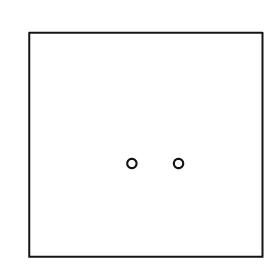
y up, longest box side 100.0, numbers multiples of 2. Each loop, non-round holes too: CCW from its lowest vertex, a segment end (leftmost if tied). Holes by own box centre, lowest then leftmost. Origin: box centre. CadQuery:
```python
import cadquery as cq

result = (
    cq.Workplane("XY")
    .moveTo(-50.0, -48.0)
    .lineTo(50.0, -48.0)
    .lineTo(50.0, 48.0)
    .lineTo(-50.0, 48.0)
    .close()
    .moveTo(-6.0, -8.0)
    .circle(2.0)
    .moveTo(14.0, -8.0)
    .circle(2.0)
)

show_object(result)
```